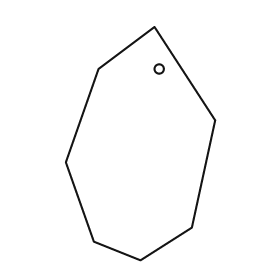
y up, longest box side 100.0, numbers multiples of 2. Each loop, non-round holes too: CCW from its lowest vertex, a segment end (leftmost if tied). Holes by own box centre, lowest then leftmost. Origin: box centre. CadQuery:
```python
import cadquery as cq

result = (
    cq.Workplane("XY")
    .moveTo(0.0, -50.0)
    .lineTo(22.0, -36.0)
    .lineTo(32.0, 10.0)
    .lineTo(6.0, 50.0)
    .lineTo(-18.0, 32.0)
    .lineTo(-32.0, -8.0)
    .lineTo(-20.0, -42.0)
    .close()
    .moveTo(8.0, 32.0)
    .circle(2.0)
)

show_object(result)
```